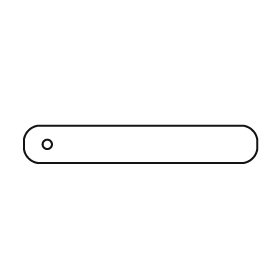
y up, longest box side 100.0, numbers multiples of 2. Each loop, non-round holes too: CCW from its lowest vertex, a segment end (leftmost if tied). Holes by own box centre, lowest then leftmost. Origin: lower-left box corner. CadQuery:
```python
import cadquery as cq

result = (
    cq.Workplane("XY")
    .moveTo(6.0, 0.0)
    .lineTo(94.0, 0.0)
    .threePointArc((98.0, 2.0), (100.0, 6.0))
    .lineTo(100.0, 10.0)
    .threePointArc((98.0, 14.0), (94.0, 16.0))
    .lineTo(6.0, 16.0)
    .threePointArc((2.0, 14.0), (0.0, 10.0))
    .lineTo(0.0, 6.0)
    .threePointArc((2.0, 2.0), (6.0, 0.0))
    .close()
    .moveTo(10.0, 8.0)
    .circle(2.0)
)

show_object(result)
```